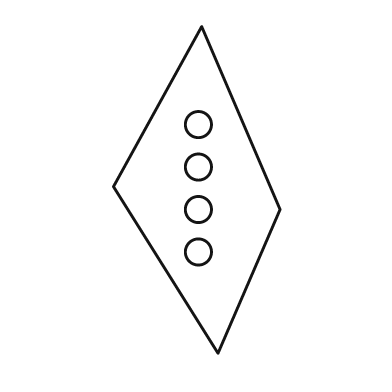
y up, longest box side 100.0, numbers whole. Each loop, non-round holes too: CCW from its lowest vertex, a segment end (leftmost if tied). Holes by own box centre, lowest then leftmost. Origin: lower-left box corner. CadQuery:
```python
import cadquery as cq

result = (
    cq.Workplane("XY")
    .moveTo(32.0, 0.0)
    .lineTo(51.0, 44.0)
    .lineTo(27.0, 100.0)
    .lineTo(0.0, 51.0)
    .close()
    .moveTo(26.0, 31.0)
    .circle(4.0)
    .moveTo(26.0, 44.0)
    .circle(4.0)
    .moveTo(26.0, 57.0)
    .circle(4.0)
    .moveTo(26.0, 70.0)
    .circle(4.0)
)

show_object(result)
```